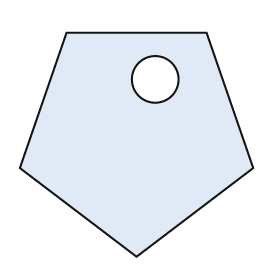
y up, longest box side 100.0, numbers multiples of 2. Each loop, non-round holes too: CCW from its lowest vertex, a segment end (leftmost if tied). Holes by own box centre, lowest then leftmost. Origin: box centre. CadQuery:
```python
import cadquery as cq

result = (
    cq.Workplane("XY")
    .moveTo(0.0, -48.0)
    .lineTo(50.0, -10.0)
    .lineTo(30.0, 48.0)
    .lineTo(-30.0, 48.0)
    .lineTo(-50.0, -10.0)
    .close()
    .moveTo(8.0, 28.0)
    .circle(10.0)
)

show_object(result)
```